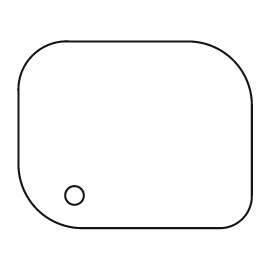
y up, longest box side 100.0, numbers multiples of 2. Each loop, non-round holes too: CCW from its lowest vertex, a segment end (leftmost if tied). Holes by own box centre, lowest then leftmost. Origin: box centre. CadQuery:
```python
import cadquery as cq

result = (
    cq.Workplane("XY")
    .moveTo(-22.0, -40.0)
    .lineTo(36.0, -40.0)
    .threePointArc((46.0, -36.0), (50.0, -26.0))
    .lineTo(50.0, 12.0)
    .threePointArc((42.0, 32.0), (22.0, 40.0))
    .lineTo(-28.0, 40.0)
    .threePointArc((-44.0, 34.0), (-50.0, 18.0))
    .lineTo(-50.0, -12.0)
    .threePointArc((-42.0, -32.0), (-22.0, -40.0))
    .close()
    .moveTo(-26.0, -26.0)
    .circle(4.0)
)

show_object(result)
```